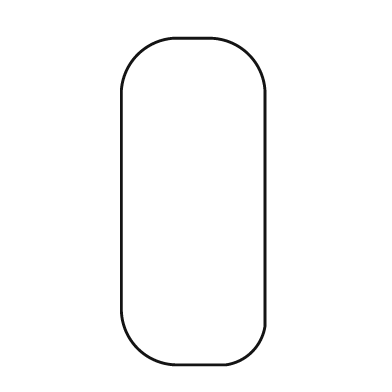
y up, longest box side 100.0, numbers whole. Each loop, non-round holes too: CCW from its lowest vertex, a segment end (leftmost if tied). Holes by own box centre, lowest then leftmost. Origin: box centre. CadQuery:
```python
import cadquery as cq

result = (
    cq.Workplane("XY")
    .moveTo(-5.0, -50.0)
    .lineTo(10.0, -50.0)
    .threePointArc((18.0, -46.0), (22.0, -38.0))
    .lineTo(22.0, 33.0)
    .threePointArc((17.0, 45.0), (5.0, 50.0))
    .lineTo(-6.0, 50.0)
    .threePointArc((-17.0, 45.0), (-22.0, 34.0))
    .lineTo(-22.0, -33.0)
    .threePointArc((-17.0, -45.0), (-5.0, -50.0))
    .close()
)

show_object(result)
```